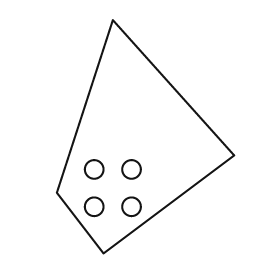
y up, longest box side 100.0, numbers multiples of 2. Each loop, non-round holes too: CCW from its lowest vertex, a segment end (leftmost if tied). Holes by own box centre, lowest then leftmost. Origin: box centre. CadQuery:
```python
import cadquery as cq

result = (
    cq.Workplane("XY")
    .moveTo(-18.0, -50.0)
    .lineTo(38.0, -8.0)
    .lineTo(-14.0, 50.0)
    .lineTo(-38.0, -24.0)
    .close()
    .moveTo(-22.0, -30.0)
    .circle(4.0)
    .moveTo(-6.0, -30.0)
    .circle(4.0)
    .moveTo(-22.0, -14.0)
    .circle(4.0)
    .moveTo(-6.0, -14.0)
    .circle(4.0)
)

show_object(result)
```